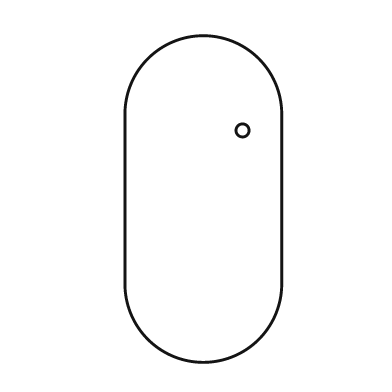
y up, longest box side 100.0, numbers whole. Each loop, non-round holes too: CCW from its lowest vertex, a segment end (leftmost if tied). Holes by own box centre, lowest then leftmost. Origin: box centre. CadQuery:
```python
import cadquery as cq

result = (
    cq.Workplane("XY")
    .moveTo(-24.0, -26.0)
    .threePointArc((0.0, -50.0), (24.0, -26.0))
    .lineTo(24.0, 26.0)
    .threePointArc((0.0, 50.0), (-24.0, 26.0))
    .close()
    .moveTo(12.0, 21.0)
    .circle(2.0)
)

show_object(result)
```